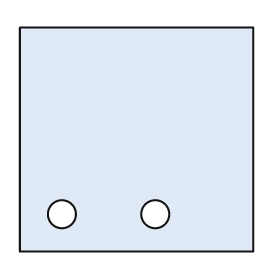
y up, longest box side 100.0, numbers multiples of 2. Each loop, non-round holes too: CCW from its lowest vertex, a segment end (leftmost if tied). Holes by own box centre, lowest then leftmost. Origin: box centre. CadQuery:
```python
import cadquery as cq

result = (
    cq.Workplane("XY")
    .moveTo(-50.0, -48.0)
    .lineTo(50.0, -48.0)
    .lineTo(50.0, 48.0)
    .lineTo(-50.0, 48.0)
    .close()
    .moveTo(-32.0, -32.0)
    .circle(6.0)
    .moveTo(8.0, -32.0)
    .circle(6.0)
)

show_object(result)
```